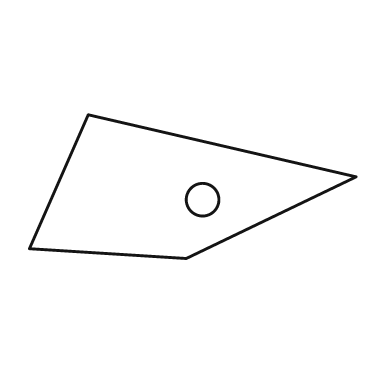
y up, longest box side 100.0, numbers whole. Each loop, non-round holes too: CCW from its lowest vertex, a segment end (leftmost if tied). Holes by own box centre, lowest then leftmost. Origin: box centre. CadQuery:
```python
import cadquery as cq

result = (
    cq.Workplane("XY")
    .moveTo(-2.0, -22.0)
    .lineTo(50.0, 3.0)
    .lineTo(-32.0, 22.0)
    .lineTo(-50.0, -19.0)
    .close()
    .moveTo(3.0, -4.0)
    .circle(5.0)
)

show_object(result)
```